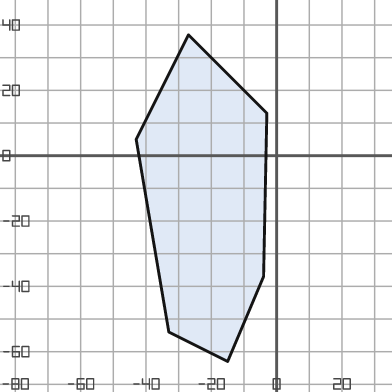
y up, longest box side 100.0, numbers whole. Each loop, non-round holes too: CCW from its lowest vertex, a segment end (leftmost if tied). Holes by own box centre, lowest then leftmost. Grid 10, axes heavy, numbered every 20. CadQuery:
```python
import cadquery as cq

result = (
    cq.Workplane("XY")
    .moveTo(-15.0, -63.0)
    .lineTo(-4.0, -37.0)
    .lineTo(-3.0, 13.0)
    .lineTo(-27.0, 37.0)
    .lineTo(-43.0, 5.0)
    .lineTo(-33.0, -54.0)
    .close()
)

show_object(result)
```